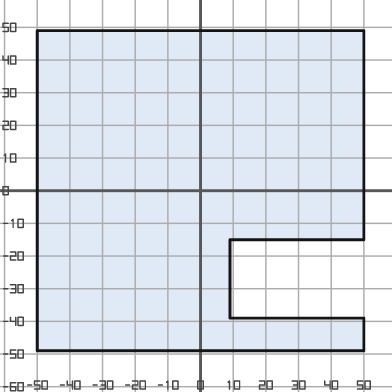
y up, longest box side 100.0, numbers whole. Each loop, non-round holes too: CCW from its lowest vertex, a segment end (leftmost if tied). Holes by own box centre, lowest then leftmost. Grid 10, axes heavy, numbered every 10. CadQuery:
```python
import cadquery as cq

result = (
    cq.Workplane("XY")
    .moveTo(-50.0, -49.0)
    .lineTo(50.0, -49.0)
    .lineTo(50.0, -39.0)
    .lineTo(9.0, -39.0)
    .lineTo(9.0, -15.0)
    .lineTo(50.0, -15.0)
    .lineTo(50.0, 49.0)
    .lineTo(-50.0, 49.0)
    .close()
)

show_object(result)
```